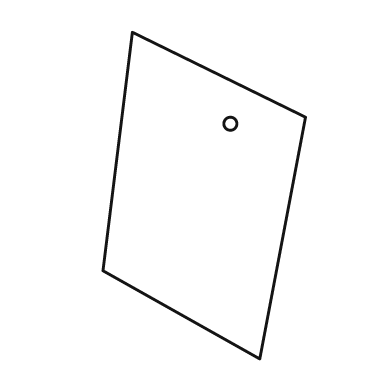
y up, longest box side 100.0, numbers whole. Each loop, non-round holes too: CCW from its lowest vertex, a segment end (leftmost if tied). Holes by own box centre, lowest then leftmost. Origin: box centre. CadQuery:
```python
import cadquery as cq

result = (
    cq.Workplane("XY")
    .moveTo(17.0, -50.0)
    .lineTo(31.0, 24.0)
    .lineTo(-22.0, 50.0)
    .lineTo(-31.0, -23.0)
    .close()
    .moveTo(8.0, 22.0)
    .circle(2.0)
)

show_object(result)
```